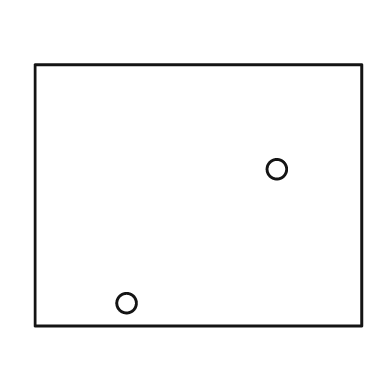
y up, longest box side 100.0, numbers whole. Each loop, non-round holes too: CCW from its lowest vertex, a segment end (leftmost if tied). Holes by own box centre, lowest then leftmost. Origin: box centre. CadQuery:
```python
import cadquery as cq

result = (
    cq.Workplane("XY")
    .moveTo(-50.0, -40.0)
    .lineTo(50.0, -40.0)
    .lineTo(50.0, 40.0)
    .lineTo(-50.0, 40.0)
    .close()
    .moveTo(-22.0, -33.0)
    .circle(3.0)
    .moveTo(24.0, 8.0)
    .circle(3.0)
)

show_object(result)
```